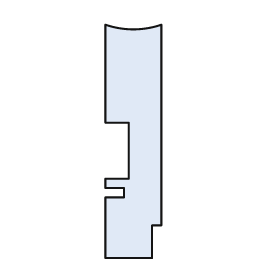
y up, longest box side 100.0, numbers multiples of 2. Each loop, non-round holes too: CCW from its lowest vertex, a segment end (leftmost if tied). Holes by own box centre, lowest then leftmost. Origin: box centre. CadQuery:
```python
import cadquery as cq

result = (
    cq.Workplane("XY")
    .moveTo(-12.0, -50.0)
    .lineTo(8.0, -50.0)
    .lineTo(8.0, -36.0)
    .lineTo(12.0, -36.0)
    .lineTo(12.0, 50.0)
    .threePointArc((0.0, 48.0), (-12.0, 50.0))
    .lineTo(-12.0, 8.0)
    .lineTo(-2.0, 8.0)
    .lineTo(-2.0, -16.0)
    .lineTo(-12.0, -16.0)
    .lineTo(-12.0, -20.0)
    .lineTo(-4.0, -20.0)
    .lineTo(-4.0, -24.0)
    .lineTo(-12.0, -24.0)
    .close()
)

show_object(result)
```